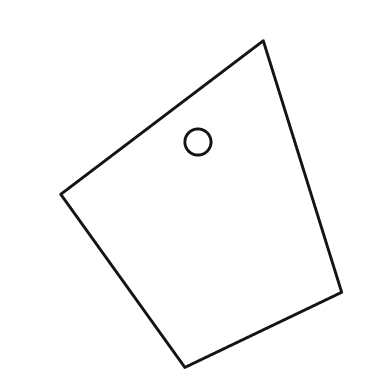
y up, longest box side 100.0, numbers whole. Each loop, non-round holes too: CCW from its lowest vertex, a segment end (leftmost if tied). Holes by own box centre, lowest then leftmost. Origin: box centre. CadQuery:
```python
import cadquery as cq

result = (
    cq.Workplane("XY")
    .moveTo(-5.0, -50.0)
    .lineTo(43.0, -27.0)
    .lineTo(19.0, 50.0)
    .lineTo(-43.0, 3.0)
    .close()
    .moveTo(-1.0, 19.0)
    .circle(4.0)
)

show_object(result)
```